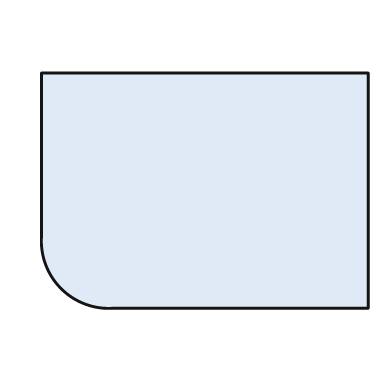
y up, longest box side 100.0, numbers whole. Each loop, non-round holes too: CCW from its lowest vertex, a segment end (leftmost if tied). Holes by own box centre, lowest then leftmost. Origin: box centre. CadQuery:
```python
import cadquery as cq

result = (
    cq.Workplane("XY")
    .moveTo(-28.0, -36.0)
    .lineTo(50.0, -36.0)
    .lineTo(50.0, 36.0)
    .lineTo(-50.0, 36.0)
    .lineTo(-50.0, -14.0)
    .threePointArc((-44.0, -30.0), (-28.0, -36.0))
    .close()
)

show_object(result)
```